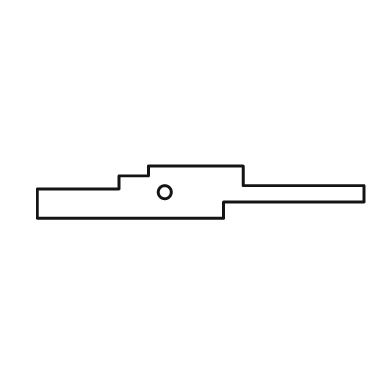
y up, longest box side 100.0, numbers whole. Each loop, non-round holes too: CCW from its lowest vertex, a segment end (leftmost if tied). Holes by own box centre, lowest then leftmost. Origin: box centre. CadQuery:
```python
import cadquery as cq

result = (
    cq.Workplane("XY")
    .moveTo(-50.0, -8.0)
    .lineTo(7.0, -8.0)
    .lineTo(7.0, -3.0)
    .lineTo(50.0, -3.0)
    .lineTo(50.0, 2.0)
    .lineTo(13.0, 2.0)
    .lineTo(13.0, 8.0)
    .lineTo(-16.0, 8.0)
    .lineTo(-16.0, 5.0)
    .lineTo(-25.0, 5.0)
    .lineTo(-25.0, 1.0)
    .lineTo(-50.0, 1.0)
    .close()
    .moveTo(-11.0, 0.0)
    .circle(2.0)
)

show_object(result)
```